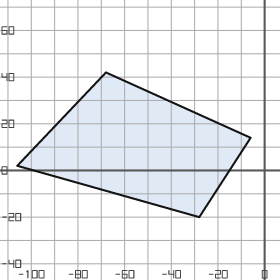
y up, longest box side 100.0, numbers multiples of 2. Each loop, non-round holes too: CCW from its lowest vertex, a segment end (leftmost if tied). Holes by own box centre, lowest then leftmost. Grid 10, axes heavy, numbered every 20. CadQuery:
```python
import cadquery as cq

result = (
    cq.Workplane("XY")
    .moveTo(-28.0, -20.0)
    .lineTo(-6.0, 14.0)
    .lineTo(-68.0, 42.0)
    .lineTo(-106.0, 2.0)
    .close()
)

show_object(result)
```